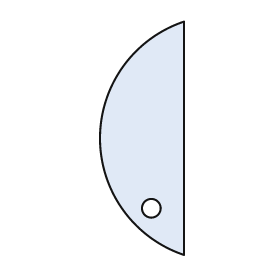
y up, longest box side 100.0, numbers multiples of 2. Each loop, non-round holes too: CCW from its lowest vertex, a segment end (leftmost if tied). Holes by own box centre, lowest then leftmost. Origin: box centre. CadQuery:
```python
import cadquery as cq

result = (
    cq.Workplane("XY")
    .moveTo(18.0, -50.0)
    .lineTo(18.0, 50.0)
    .threePointArc((-18.0, 0.0), (18.0, -50.0))
    .close()
    .moveTo(4.0, -30.0)
    .circle(4.0)
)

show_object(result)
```